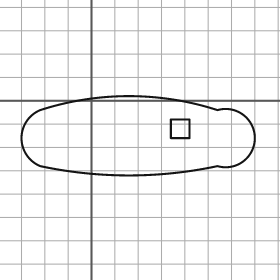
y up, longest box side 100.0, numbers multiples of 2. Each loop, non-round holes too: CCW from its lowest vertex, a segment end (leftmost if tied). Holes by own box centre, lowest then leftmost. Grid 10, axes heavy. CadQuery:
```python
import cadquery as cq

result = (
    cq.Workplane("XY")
    .moveTo(-22.0, -28.0)
    .threePointArc((16.0, -32.0), (54.0, -28.0))
    .threePointArc((70.0, -16.0), (54.0, -4.0))
    .threePointArc((16.0, 2.0), (-22.0, -4.0))
    .threePointArc((-30.0, -16.0), (-22.0, -28.0))
    .close()
    .moveTo(34.0, -16.0)
    .lineTo(42.0, -16.0)
    .lineTo(42.0, -8.0)
    .lineTo(34.0, -8.0)
    .close()
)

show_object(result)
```